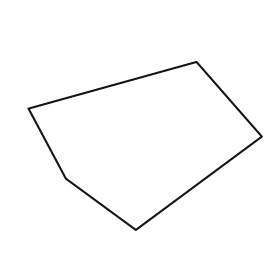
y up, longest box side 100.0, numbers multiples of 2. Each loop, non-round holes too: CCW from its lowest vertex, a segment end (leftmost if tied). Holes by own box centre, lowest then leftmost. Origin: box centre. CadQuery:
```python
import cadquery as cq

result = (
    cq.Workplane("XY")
    .moveTo(-4.0, -36.0)
    .lineTo(50.0, 4.0)
    .lineTo(22.0, 36.0)
    .lineTo(-50.0, 16.0)
    .lineTo(-34.0, -14.0)
    .close()
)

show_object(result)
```